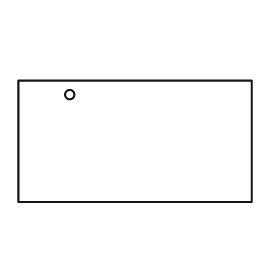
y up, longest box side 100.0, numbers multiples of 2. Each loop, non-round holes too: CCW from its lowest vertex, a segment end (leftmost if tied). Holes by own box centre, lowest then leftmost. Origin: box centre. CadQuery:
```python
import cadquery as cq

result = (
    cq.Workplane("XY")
    .moveTo(-50.0, -26.0)
    .lineTo(50.0, -26.0)
    .lineTo(50.0, 26.0)
    .lineTo(-50.0, 26.0)
    .close()
    .moveTo(-28.0, 20.0)
    .circle(2.0)
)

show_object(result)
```